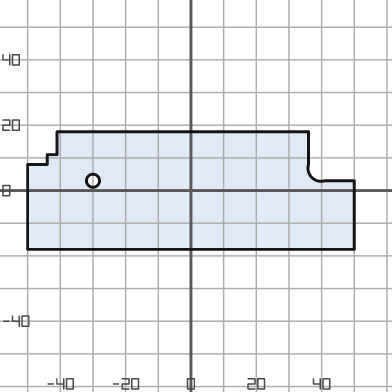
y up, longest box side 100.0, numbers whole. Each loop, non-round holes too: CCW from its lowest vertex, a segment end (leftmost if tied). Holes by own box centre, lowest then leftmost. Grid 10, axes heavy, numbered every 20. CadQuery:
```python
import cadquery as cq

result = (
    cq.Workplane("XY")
    .moveTo(-50.0, -18.0)
    .lineTo(50.0, -18.0)
    .lineTo(50.0, 3.0)
    .lineTo(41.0, 3.0)
    .threePointArc((37.0, 4.0), (36.0, 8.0))
    .lineTo(36.0, 18.0)
    .lineTo(-41.0, 18.0)
    .lineTo(-41.0, 11.0)
    .lineTo(-44.0, 11.0)
    .lineTo(-44.0, 8.0)
    .lineTo(-50.0, 8.0)
    .close()
    .moveTo(-30.0, 3.0)
    .circle(2.0)
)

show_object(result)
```